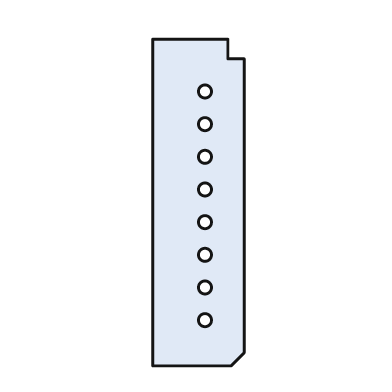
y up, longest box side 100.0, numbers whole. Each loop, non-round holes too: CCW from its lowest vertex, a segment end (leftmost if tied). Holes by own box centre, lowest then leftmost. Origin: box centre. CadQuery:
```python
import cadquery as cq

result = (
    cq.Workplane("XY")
    .moveTo(-14.0, -50.0)
    .lineTo(10.0, -50.0)
    .lineTo(14.0, -46.0)
    .lineTo(14.0, 44.0)
    .lineTo(9.0, 44.0)
    .lineTo(9.0, 50.0)
    .lineTo(-14.0, 50.0)
    .close()
    .moveTo(2.0, -36.0)
    .circle(2.0)
    .moveTo(2.0, -26.0)
    .circle(2.0)
    .moveTo(2.0, -16.0)
    .circle(2.0)
    .moveTo(2.0, -6.0)
    .circle(2.0)
    .moveTo(2.0, 4.0)
    .circle(2.0)
    .moveTo(2.0, 14.0)
    .circle(2.0)
    .moveTo(2.0, 24.0)
    .circle(2.0)
    .moveTo(2.0, 34.0)
    .circle(2.0)
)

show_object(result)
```